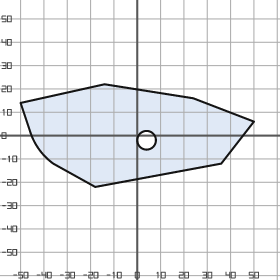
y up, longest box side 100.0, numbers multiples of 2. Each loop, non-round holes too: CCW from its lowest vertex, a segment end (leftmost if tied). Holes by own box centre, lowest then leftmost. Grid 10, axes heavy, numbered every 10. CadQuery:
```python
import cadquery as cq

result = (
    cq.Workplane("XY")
    .moveTo(-18.0, -22.0)
    .lineTo(36.0, -12.0)
    .lineTo(50.0, 6.0)
    .lineTo(24.0, 16.0)
    .lineTo(-14.0, 22.0)
    .lineTo(-50.0, 14.0)
    .lineTo(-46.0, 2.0)
    .threePointArc((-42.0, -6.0), (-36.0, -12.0))
    .close()
    .moveTo(4.0, -2.0)
    .circle(4.0)
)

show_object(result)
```